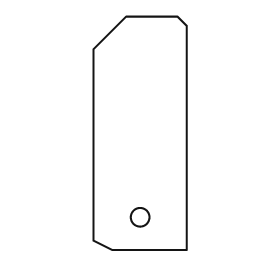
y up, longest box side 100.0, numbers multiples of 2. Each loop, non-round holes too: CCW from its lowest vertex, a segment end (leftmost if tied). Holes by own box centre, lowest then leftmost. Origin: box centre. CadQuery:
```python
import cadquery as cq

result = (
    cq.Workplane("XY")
    .moveTo(-12.0, -50.0)
    .lineTo(20.0, -50.0)
    .lineTo(20.0, 46.0)
    .lineTo(16.0, 50.0)
    .lineTo(-6.0, 50.0)
    .lineTo(-20.0, 36.0)
    .lineTo(-20.0, -46.0)
    .close()
    .moveTo(0.0, -36.0)
    .circle(4.0)
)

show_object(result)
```